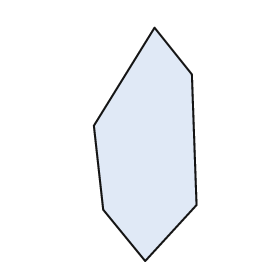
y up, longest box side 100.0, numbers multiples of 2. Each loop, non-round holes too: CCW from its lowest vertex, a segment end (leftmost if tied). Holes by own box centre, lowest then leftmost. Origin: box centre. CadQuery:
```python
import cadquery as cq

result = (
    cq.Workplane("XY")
    .moveTo(0.0, -50.0)
    .lineTo(22.0, -26.0)
    .lineTo(20.0, 30.0)
    .lineTo(4.0, 50.0)
    .lineTo(-22.0, 8.0)
    .lineTo(-18.0, -28.0)
    .close()
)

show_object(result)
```